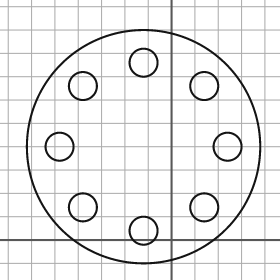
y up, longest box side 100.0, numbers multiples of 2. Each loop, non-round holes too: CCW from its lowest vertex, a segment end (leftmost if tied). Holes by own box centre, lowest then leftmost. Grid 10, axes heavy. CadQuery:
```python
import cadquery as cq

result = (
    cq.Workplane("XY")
    .moveTo(-12.0, 40.0)
    .circle(50.0)
    .moveTo(-12.0, 4.0)
    .circle(6.0)
    .moveTo(-38.0, 14.0)
    .circle(6.0)
    .moveTo(14.0, 14.0)
    .circle(6.0)
    .moveTo(-48.0, 40.0)
    .circle(6.0)
    .moveTo(24.0, 40.0)
    .circle(6.0)
    .moveTo(-38.0, 66.0)
    .circle(6.0)
    .moveTo(14.0, 66.0)
    .circle(6.0)
    .moveTo(-12.0, 76.0)
    .circle(6.0)
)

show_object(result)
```